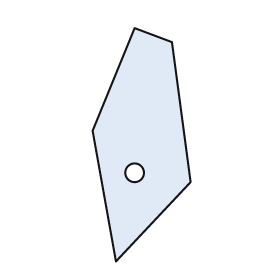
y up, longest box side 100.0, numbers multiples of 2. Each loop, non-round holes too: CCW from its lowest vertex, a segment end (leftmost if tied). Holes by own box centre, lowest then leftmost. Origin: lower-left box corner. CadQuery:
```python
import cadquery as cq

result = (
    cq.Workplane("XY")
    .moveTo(10.0, 0.0)
    .lineTo(42.0, 34.0)
    .lineTo(34.0, 94.0)
    .lineTo(18.0, 100.0)
    .lineTo(0.0, 56.0)
    .close()
    .moveTo(18.0, 38.0)
    .circle(4.0)
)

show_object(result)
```